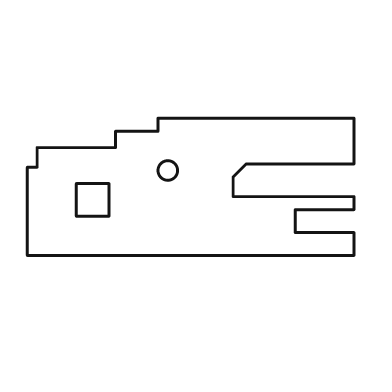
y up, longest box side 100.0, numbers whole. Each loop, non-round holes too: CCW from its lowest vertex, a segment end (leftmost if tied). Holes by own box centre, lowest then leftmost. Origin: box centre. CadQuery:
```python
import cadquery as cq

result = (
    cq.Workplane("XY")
    .moveTo(-50.0, -21.0)
    .lineTo(50.0, -21.0)
    .lineTo(50.0, -14.0)
    .lineTo(32.0, -14.0)
    .lineTo(32.0, -7.0)
    .lineTo(50.0, -7.0)
    .lineTo(50.0, -3.0)
    .lineTo(13.0, -3.0)
    .lineTo(13.0, 3.0)
    .lineTo(17.0, 7.0)
    .lineTo(50.0, 7.0)
    .lineTo(50.0, 21.0)
    .lineTo(-10.0, 21.0)
    .lineTo(-10.0, 17.0)
    .lineTo(-23.0, 17.0)
    .lineTo(-23.0, 12.0)
    .lineTo(-47.0, 12.0)
    .lineTo(-47.0, 6.0)
    .lineTo(-50.0, 6.0)
    .close()
    .moveTo(-35.0, -9.0)
    .lineTo(-25.0, -9.0)
    .lineTo(-25.0, 1.0)
    .lineTo(-35.0, 1.0)
    .close()
    .moveTo(-7.0, 5.0)
    .circle(3.0)
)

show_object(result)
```